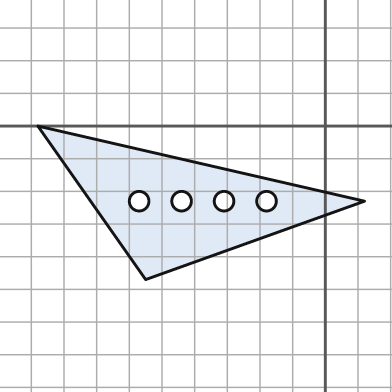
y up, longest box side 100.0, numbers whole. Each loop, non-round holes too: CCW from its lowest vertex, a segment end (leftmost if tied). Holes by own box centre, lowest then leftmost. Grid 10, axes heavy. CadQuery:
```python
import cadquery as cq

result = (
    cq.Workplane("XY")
    .moveTo(-55.0, -47.0)
    .lineTo(12.0, -23.0)
    .lineTo(-88.0, 0.0)
    .close()
    .moveTo(-57.0, -23.0)
    .circle(3.0)
    .moveTo(-44.0, -23.0)
    .circle(3.0)
    .moveTo(-31.0, -23.0)
    .circle(3.0)
    .moveTo(-18.0, -23.0)
    .circle(3.0)
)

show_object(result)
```